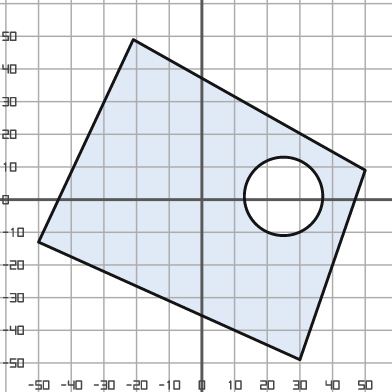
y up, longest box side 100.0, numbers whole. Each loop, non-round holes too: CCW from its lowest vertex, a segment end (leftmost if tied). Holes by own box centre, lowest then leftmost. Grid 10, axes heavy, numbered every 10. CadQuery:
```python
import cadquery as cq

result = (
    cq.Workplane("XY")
    .moveTo(30.0, -49.0)
    .lineTo(50.0, 9.0)
    .lineTo(-21.0, 49.0)
    .lineTo(-50.0, -13.0)
    .close()
    .moveTo(25.0, 1.0)
    .circle(12.0)
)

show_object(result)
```